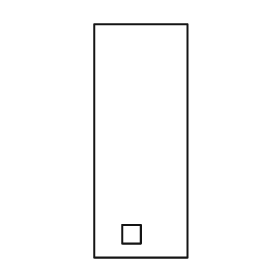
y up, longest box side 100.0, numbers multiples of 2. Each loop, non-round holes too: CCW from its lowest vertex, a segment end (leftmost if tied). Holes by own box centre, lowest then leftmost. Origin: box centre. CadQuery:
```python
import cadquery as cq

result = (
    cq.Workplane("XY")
    .moveTo(-20.0, -50.0)
    .lineTo(20.0, -50.0)
    .lineTo(20.0, 50.0)
    .lineTo(-20.0, 50.0)
    .close()
    .moveTo(-8.0, -44.0)
    .lineTo(0.0, -44.0)
    .lineTo(0.0, -36.0)
    .lineTo(-8.0, -36.0)
    .close()
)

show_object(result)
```